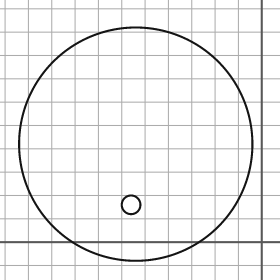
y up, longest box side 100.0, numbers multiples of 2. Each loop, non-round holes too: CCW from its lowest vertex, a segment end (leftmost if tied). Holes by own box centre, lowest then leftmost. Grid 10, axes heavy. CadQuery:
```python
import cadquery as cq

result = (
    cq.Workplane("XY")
    .moveTo(-54.0, 42.0)
    .circle(50.0)
    .moveTo(-56.0, 16.0)
    .circle(4.0)
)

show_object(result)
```